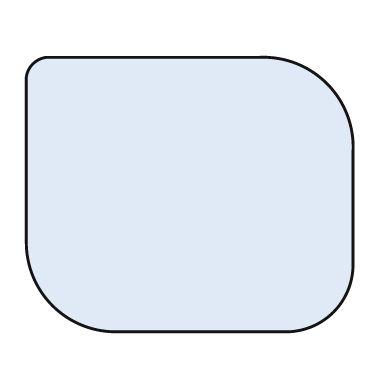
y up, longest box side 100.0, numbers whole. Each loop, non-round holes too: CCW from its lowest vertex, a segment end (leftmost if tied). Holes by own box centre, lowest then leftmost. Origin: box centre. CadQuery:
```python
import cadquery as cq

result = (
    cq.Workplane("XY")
    .moveTo(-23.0, -42.0)
    .lineTo(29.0, -42.0)
    .threePointArc((44.0, -36.0), (50.0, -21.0))
    .lineTo(50.0, 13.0)
    .threePointArc((42.0, 34.0), (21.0, 42.0))
    .lineTo(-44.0, 42.0)
    .threePointArc((-48.0, 40.0), (-50.0, 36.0))
    .lineTo(-50.0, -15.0)
    .threePointArc((-42.0, -34.0), (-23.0, -42.0))
    .close()
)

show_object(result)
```